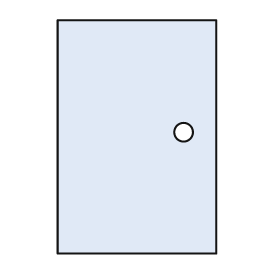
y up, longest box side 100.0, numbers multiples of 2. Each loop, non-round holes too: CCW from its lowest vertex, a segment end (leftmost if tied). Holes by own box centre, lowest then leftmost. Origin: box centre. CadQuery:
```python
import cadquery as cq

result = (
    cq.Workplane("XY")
    .moveTo(-34.0, -50.0)
    .lineTo(34.0, -50.0)
    .lineTo(34.0, 50.0)
    .lineTo(-34.0, 50.0)
    .close()
    .moveTo(20.0, 2.0)
    .circle(4.0)
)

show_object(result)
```